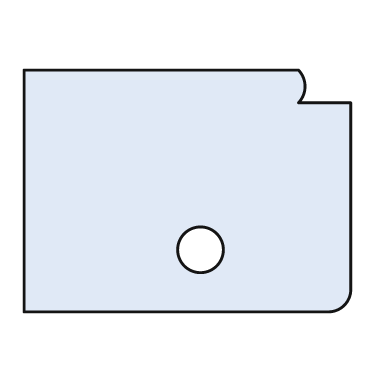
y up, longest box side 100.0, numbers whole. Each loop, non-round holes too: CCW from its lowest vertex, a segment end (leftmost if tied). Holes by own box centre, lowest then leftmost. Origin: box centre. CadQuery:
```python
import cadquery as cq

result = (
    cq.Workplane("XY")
    .moveTo(-50.0, -37.0)
    .lineTo(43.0, -37.0)
    .threePointArc((48.0, -35.0), (50.0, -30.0))
    .lineTo(50.0, 27.0)
    .lineTo(34.0, 27.0)
    .threePointArc((36.0, 32.0), (34.0, 37.0))
    .lineTo(-50.0, 37.0)
    .close()
    .moveTo(4.0, -18.0)
    .circle(7.0)
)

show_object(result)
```